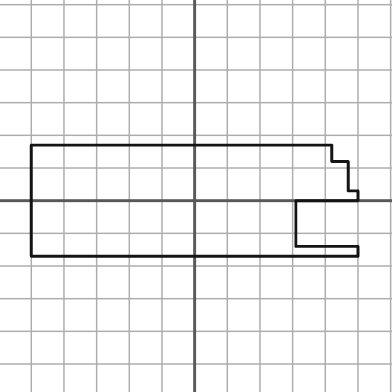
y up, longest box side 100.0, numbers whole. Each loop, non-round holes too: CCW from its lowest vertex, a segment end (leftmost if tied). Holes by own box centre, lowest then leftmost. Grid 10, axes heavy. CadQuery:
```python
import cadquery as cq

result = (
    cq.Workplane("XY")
    .moveTo(-50.0, -17.0)
    .lineTo(50.0, -17.0)
    .lineTo(50.0, -14.0)
    .lineTo(31.0, -14.0)
    .lineTo(31.0, 0.0)
    .lineTo(50.0, 0.0)
    .lineTo(50.0, 3.0)
    .lineTo(47.0, 3.0)
    .lineTo(47.0, 12.0)
    .lineTo(42.0, 12.0)
    .lineTo(42.0, 17.0)
    .lineTo(-50.0, 17.0)
    .close()
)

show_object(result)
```